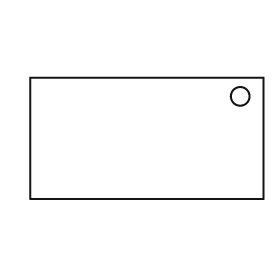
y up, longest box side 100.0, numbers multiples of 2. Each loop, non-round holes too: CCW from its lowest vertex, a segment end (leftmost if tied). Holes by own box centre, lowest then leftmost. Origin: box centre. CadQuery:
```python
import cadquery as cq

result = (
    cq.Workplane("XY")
    .moveTo(-50.0, -26.0)
    .lineTo(50.0, -26.0)
    .lineTo(50.0, 26.0)
    .lineTo(-50.0, 26.0)
    .close()
    .moveTo(40.0, 18.0)
    .circle(4.0)
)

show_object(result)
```